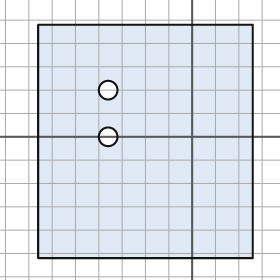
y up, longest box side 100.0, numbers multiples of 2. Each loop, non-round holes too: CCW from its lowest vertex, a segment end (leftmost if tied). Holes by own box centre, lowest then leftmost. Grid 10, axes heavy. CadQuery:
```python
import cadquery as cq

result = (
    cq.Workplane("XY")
    .moveTo(-66.0, -52.0)
    .lineTo(26.0, -52.0)
    .lineTo(26.0, 48.0)
    .lineTo(-66.0, 48.0)
    .close()
    .moveTo(-36.0, 0.0)
    .circle(4.0)
    .moveTo(-36.0, 20.0)
    .circle(4.0)
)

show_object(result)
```